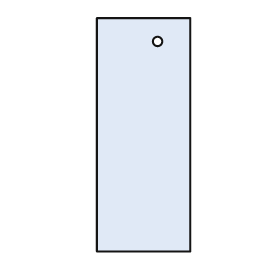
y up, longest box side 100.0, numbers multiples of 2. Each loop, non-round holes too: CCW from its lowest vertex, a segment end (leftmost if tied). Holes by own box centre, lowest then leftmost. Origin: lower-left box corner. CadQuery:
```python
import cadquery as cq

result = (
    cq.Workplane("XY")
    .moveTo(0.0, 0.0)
    .lineTo(40.0, 0.0)
    .lineTo(40.0, 100.0)
    .lineTo(0.0, 100.0)
    .close()
    .moveTo(26.0, 90.0)
    .circle(2.0)
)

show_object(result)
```